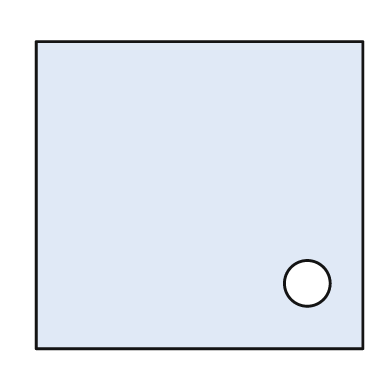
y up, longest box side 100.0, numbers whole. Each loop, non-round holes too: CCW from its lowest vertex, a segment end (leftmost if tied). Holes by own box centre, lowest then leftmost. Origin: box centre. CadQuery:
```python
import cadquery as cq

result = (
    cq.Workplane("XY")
    .moveTo(-50.0, -47.0)
    .lineTo(50.0, -47.0)
    .lineTo(50.0, 47.0)
    .lineTo(-50.0, 47.0)
    .close()
    .moveTo(33.0, -27.0)
    .circle(7.0)
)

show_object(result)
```